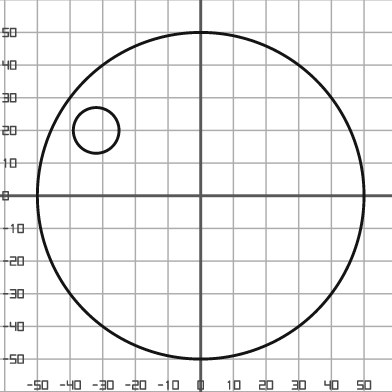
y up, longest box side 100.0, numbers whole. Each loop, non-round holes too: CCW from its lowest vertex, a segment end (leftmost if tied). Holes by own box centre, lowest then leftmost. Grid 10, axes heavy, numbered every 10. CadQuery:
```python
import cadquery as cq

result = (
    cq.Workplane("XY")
    .moveTo(0.0, 0.0)
    .circle(50.0)
    .moveTo(-32.0, 20.0)
    .circle(7.0)
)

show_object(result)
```